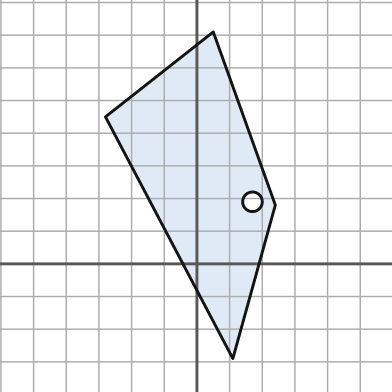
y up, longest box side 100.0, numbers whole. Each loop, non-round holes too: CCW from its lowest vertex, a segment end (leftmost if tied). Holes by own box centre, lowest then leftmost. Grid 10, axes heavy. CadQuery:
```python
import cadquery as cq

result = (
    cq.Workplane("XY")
    .moveTo(11.0, -29.0)
    .lineTo(24.0, 18.0)
    .lineTo(5.0, 71.0)
    .lineTo(-28.0, 45.0)
    .close()
    .moveTo(17.0, 19.0)
    .circle(3.0)
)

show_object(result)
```